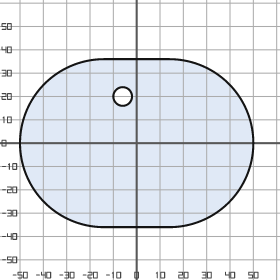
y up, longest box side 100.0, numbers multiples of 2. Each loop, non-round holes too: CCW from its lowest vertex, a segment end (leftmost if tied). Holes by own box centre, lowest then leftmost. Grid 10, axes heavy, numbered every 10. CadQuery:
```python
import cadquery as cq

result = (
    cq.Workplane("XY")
    .moveTo(-14.0, -36.0)
    .lineTo(14.0, -36.0)
    .threePointArc((50.0, 0.0), (14.0, 36.0))
    .lineTo(-14.0, 36.0)
    .threePointArc((-50.0, 0.0), (-14.0, -36.0))
    .close()
    .moveTo(-6.0, 20.0)
    .circle(4.0)
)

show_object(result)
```